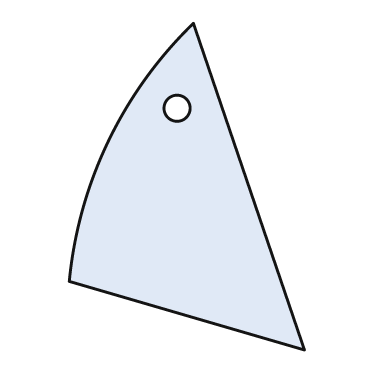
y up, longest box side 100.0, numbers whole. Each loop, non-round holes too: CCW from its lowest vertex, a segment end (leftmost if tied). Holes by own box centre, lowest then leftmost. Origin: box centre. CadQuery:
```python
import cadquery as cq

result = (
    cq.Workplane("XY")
    .moveTo(36.0, -50.0)
    .lineTo(2.0, 50.0)
    .threePointArc((-24.0, 14.0), (-36.0, -29.0))
    .close()
    .moveTo(-3.0, 24.0)
    .circle(4.0)
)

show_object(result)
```